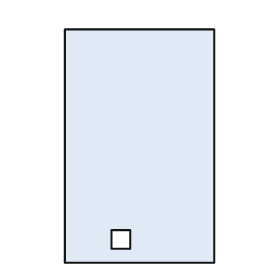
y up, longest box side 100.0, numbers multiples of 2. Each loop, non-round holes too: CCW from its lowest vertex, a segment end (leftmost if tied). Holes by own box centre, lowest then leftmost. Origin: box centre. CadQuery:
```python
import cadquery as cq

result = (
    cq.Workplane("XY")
    .moveTo(-32.0, -50.0)
    .lineTo(32.0, -50.0)
    .lineTo(32.0, 50.0)
    .lineTo(-32.0, 50.0)
    .close()
    .moveTo(-12.0, -44.0)
    .lineTo(-4.0, -44.0)
    .lineTo(-4.0, -36.0)
    .lineTo(-12.0, -36.0)
    .close()
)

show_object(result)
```